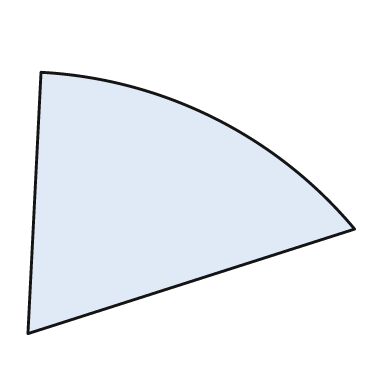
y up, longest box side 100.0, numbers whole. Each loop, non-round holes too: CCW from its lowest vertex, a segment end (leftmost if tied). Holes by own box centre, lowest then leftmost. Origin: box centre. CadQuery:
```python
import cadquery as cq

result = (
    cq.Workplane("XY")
    .moveTo(-50.0, -40.0)
    .lineTo(50.0, -8.0)
    .threePointArc((7.0, 26.0), (-46.0, 40.0))
    .close()
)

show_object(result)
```